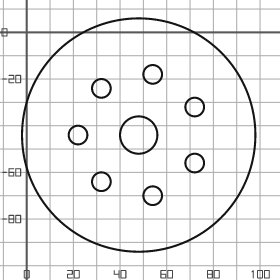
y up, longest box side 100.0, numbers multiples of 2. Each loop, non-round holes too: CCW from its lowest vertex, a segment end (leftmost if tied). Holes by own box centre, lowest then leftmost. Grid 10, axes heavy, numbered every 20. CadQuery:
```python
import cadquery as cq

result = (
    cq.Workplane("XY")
    .moveTo(48.0, -44.0)
    .circle(50.0)
    .moveTo(54.0, -70.0)
    .circle(4.0)
    .moveTo(32.0, -64.0)
    .circle(4.0)
    .moveTo(72.0, -56.0)
    .circle(4.0)
    .moveTo(22.0, -44.0)
    .circle(4.0)
    .moveTo(48.0, -44.0)
    .circle(8.0)
    .moveTo(72.0, -32.0)
    .circle(4.0)
    .moveTo(32.0, -24.0)
    .circle(4.0)
    .moveTo(54.0, -18.0)
    .circle(4.0)
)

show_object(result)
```